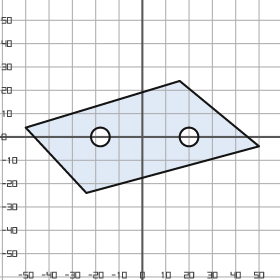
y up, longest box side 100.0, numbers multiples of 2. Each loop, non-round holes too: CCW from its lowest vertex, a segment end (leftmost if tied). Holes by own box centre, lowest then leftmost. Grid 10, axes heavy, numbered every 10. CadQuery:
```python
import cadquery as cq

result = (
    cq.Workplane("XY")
    .moveTo(-24.0, -24.0)
    .lineTo(50.0, -4.0)
    .lineTo(16.0, 24.0)
    .lineTo(-50.0, 4.0)
    .close()
    .moveTo(-18.0, 0.0)
    .circle(4.0)
    .moveTo(20.0, 0.0)
    .circle(4.0)
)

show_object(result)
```